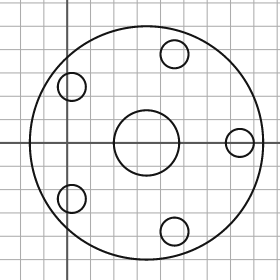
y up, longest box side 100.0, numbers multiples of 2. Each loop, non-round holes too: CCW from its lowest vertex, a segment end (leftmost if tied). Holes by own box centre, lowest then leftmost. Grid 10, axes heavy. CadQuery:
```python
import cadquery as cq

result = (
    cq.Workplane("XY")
    .moveTo(34.0, 0.0)
    .circle(50.0)
    .moveTo(46.0, -38.0)
    .circle(6.0)
    .moveTo(2.0, -24.0)
    .circle(6.0)
    .moveTo(34.0, 0.0)
    .circle(14.0)
    .moveTo(74.0, 0.0)
    .circle(6.0)
    .moveTo(2.0, 24.0)
    .circle(6.0)
    .moveTo(46.0, 38.0)
    .circle(6.0)
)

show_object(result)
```